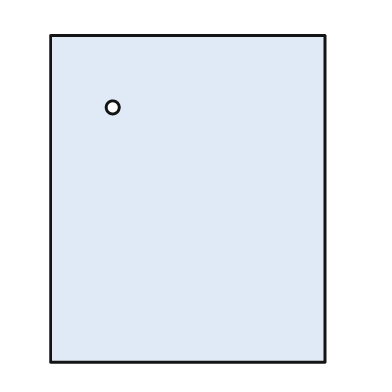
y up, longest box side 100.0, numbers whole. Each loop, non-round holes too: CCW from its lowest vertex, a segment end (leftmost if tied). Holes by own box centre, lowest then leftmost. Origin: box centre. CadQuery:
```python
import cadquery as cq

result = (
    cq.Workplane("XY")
    .moveTo(-42.0, -50.0)
    .lineTo(42.0, -50.0)
    .lineTo(42.0, 50.0)
    .lineTo(-42.0, 50.0)
    .close()
    .moveTo(-23.0, 28.0)
    .circle(2.0)
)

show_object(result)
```